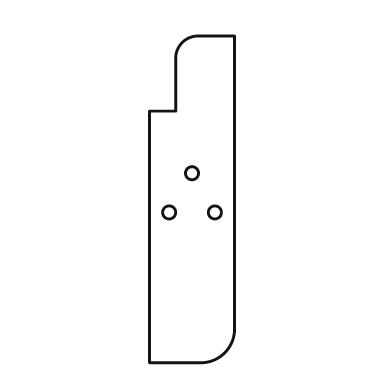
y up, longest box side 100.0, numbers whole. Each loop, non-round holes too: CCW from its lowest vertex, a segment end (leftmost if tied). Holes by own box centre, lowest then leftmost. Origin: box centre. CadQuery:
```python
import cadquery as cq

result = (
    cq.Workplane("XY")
    .moveTo(-13.0, -50.0)
    .lineTo(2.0, -50.0)
    .threePointArc((10.0, -47.0), (13.0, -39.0))
    .lineTo(13.0, 50.0)
    .lineTo(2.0, 50.0)
    .threePointArc((-3.0, 48.0), (-5.0, 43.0))
    .lineTo(-5.0, 27.0)
    .lineTo(-13.0, 27.0)
    .close()
    .moveTo(-7.0, -4.0)
    .circle(2.0)
    .moveTo(7.0, -4.0)
    .circle(2.0)
    .moveTo(0.0, 8.0)
    .circle(2.0)
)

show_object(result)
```